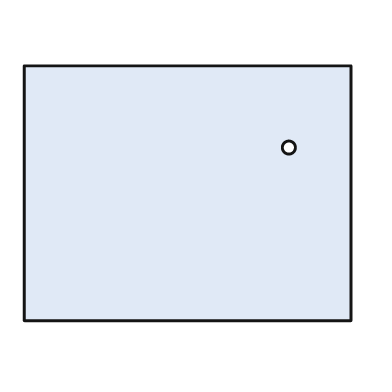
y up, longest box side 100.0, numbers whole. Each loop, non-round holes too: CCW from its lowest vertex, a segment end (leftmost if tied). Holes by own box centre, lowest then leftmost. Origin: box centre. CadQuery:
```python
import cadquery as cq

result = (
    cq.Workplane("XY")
    .moveTo(-50.0, -39.0)
    .lineTo(50.0, -39.0)
    .lineTo(50.0, 39.0)
    .lineTo(-50.0, 39.0)
    .close()
    .moveTo(31.0, 14.0)
    .circle(2.0)
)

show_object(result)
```